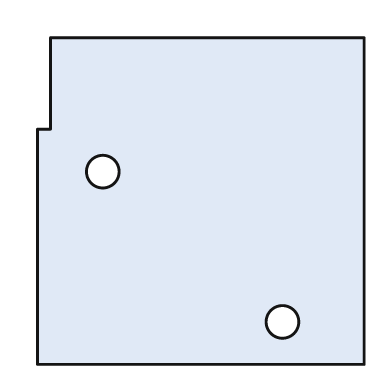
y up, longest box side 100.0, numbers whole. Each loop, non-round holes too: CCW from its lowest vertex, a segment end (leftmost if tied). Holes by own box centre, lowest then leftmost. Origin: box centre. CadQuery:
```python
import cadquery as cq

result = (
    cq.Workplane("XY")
    .moveTo(-50.0, -50.0)
    .lineTo(50.0, -50.0)
    .lineTo(50.0, 50.0)
    .lineTo(-46.0, 50.0)
    .lineTo(-46.0, 22.0)
    .lineTo(-50.0, 22.0)
    .close()
    .moveTo(25.0, -37.0)
    .circle(5.0)
    .moveTo(-30.0, 9.0)
    .circle(5.0)
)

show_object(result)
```